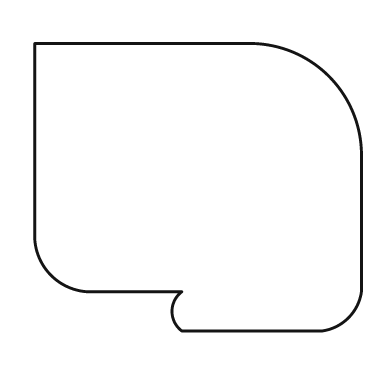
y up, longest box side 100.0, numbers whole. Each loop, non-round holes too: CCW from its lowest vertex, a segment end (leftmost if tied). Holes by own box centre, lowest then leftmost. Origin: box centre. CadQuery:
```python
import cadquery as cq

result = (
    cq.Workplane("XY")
    .moveTo(-5.0, -44.0)
    .lineTo(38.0, -44.0)
    .threePointArc((46.0, -40.0), (50.0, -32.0))
    .lineTo(50.0, 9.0)
    .threePointArc((40.0, 34.0), (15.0, 44.0))
    .lineTo(-50.0, 44.0)
    .lineTo(-50.0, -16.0)
    .threePointArc((-45.0, -27.0), (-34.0, -32.0))
    .lineTo(-5.0, -32.0)
    .threePointArc((-8.0, -38.0), (-5.0, -44.0))
    .close()
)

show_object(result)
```